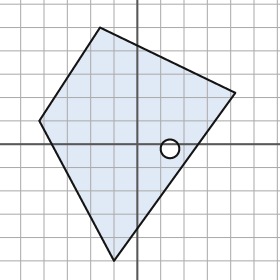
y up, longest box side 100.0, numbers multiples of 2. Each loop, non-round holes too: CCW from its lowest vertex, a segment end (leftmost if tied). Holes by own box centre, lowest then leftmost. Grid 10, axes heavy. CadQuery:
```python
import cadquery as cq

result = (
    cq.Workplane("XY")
    .moveTo(-10.0, -50.0)
    .lineTo(42.0, 22.0)
    .lineTo(-16.0, 50.0)
    .lineTo(-42.0, 10.0)
    .close()
    .moveTo(14.0, -2.0)
    .circle(4.0)
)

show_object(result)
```